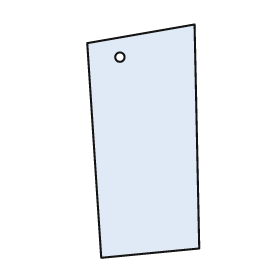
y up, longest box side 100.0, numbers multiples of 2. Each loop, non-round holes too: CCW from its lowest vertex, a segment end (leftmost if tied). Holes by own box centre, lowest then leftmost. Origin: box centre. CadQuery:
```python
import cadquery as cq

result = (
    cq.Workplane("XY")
    .moveTo(-18.0, -50.0)
    .lineTo(24.0, -46.0)
    .lineTo(22.0, 50.0)
    .lineTo(-24.0, 42.0)
    .close()
    .moveTo(-10.0, 36.0)
    .circle(2.0)
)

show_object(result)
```